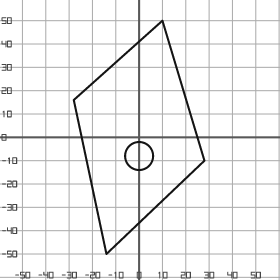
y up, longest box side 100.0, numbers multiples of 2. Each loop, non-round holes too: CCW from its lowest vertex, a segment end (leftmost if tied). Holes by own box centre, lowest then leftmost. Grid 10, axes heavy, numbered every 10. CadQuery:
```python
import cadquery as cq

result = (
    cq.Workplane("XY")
    .moveTo(-14.0, -50.0)
    .lineTo(28.0, -10.0)
    .lineTo(10.0, 50.0)
    .lineTo(-28.0, 16.0)
    .close()
    .moveTo(0.0, -8.0)
    .circle(6.0)
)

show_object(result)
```